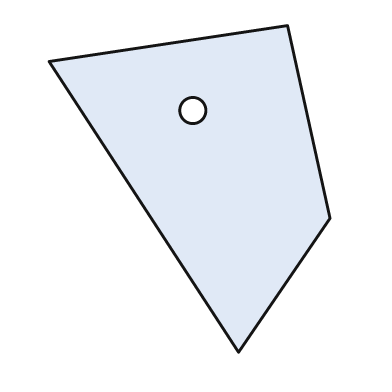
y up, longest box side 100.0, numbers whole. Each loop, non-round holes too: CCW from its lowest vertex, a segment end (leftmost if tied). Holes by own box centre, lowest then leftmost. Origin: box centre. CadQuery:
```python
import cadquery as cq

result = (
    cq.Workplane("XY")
    .moveTo(15.0, -50.0)
    .lineTo(43.0, -9.0)
    .lineTo(30.0, 50.0)
    .lineTo(-43.0, 39.0)
    .close()
    .moveTo(1.0, 24.0)
    .circle(4.0)
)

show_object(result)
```